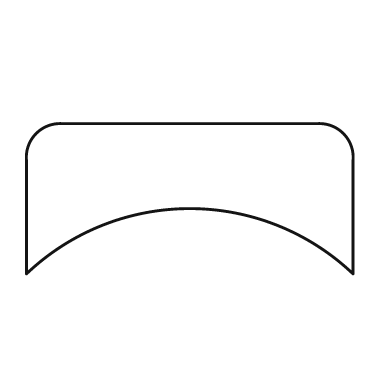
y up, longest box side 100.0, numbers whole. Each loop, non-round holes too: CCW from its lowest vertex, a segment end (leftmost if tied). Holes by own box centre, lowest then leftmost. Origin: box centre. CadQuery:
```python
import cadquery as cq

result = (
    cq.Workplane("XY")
    .moveTo(-50.0, -23.0)
    .threePointArc((0.0, -3.0), (50.0, -23.0))
    .lineTo(50.0, 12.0)
    .threePointArc((47.0, 20.0), (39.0, 23.0))
    .lineTo(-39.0, 23.0)
    .threePointArc((-47.0, 20.0), (-50.0, 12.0))
    .close()
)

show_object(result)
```